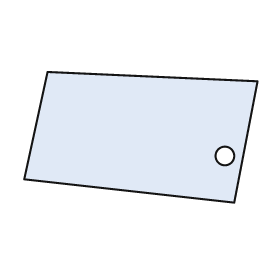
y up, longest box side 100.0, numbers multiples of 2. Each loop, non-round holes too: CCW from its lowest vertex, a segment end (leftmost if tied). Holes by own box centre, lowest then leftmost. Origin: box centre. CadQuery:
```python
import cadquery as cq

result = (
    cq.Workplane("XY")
    .moveTo(40.0, -28.0)
    .lineTo(50.0, 24.0)
    .lineTo(-40.0, 28.0)
    .lineTo(-50.0, -18.0)
    .close()
    .moveTo(36.0, -8.0)
    .circle(4.0)
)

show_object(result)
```